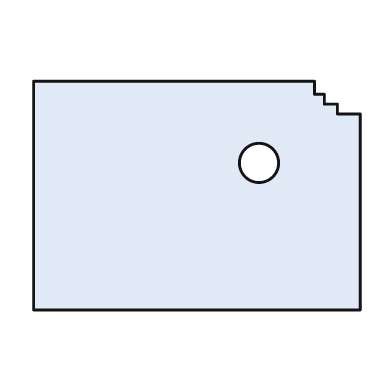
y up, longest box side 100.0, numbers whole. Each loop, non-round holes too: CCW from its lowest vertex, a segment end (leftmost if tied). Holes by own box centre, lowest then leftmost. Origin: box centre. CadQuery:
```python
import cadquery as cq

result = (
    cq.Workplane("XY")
    .moveTo(-50.0, -35.0)
    .lineTo(50.0, -35.0)
    .lineTo(50.0, 25.0)
    .lineTo(43.0, 25.0)
    .lineTo(43.0, 28.0)
    .lineTo(39.0, 28.0)
    .lineTo(39.0, 31.0)
    .lineTo(36.0, 31.0)
    .lineTo(36.0, 35.0)
    .lineTo(-50.0, 35.0)
    .close()
    .moveTo(19.0, 10.0)
    .circle(6.0)
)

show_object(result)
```